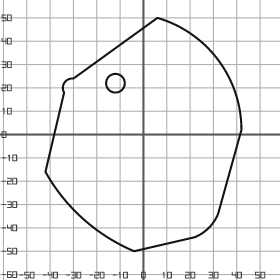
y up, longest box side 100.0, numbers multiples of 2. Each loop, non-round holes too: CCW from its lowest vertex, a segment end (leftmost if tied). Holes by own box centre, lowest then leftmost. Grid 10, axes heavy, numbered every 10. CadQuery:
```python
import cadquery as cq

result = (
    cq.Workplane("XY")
    .moveTo(-4.0, -50.0)
    .lineTo(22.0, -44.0)
    .threePointArc((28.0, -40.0), (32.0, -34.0))
    .lineTo(42.0, 2.0)
    .threePointArc((32.0, 32.0), (6.0, 50.0))
    .lineTo(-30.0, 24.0)
    .threePointArc((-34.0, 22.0), (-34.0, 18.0))
    .lineTo(-42.0, -16.0)
    .threePointArc((-26.0, -36.0), (-4.0, -50.0))
    .close()
    .moveTo(-12.0, 22.0)
    .circle(4.0)
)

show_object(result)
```